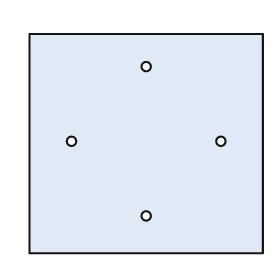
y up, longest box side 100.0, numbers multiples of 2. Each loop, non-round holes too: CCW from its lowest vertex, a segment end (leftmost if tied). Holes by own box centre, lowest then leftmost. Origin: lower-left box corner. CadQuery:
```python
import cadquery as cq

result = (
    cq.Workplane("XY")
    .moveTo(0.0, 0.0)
    .lineTo(100.0, 0.0)
    .lineTo(100.0, 94.0)
    .lineTo(0.0, 94.0)
    .close()
    .moveTo(50.0, 16.0)
    .circle(2.0)
    .moveTo(18.0, 48.0)
    .circle(2.0)
    .moveTo(82.0, 48.0)
    .circle(2.0)
    .moveTo(50.0, 80.0)
    .circle(2.0)
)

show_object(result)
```